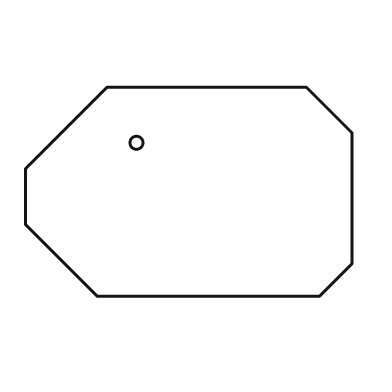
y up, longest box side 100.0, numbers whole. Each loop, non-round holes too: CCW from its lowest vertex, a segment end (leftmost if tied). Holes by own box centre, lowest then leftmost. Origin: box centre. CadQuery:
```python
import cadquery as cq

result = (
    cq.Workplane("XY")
    .moveTo(-28.0, -32.0)
    .lineTo(40.0, -32.0)
    .lineTo(50.0, -22.0)
    .lineTo(50.0, 18.0)
    .lineTo(36.0, 32.0)
    .lineTo(-25.0, 32.0)
    .lineTo(-50.0, 7.0)
    .lineTo(-50.0, -10.0)
    .close()
    .moveTo(-16.0, 15.0)
    .circle(2.0)
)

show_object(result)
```